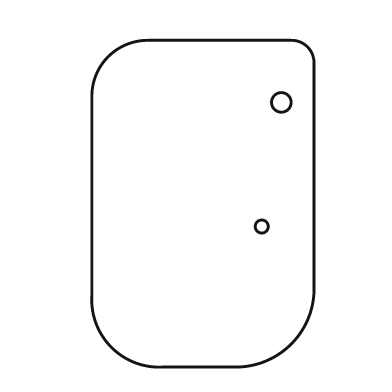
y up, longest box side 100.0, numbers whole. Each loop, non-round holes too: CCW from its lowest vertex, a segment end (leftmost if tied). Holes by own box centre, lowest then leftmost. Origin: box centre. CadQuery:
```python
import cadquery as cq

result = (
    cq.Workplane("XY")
    .moveTo(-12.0, -50.0)
    .lineTo(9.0, -50.0)
    .threePointArc((27.0, -43.0), (34.0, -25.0))
    .lineTo(34.0, 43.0)
    .threePointArc((32.0, 48.0), (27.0, 50.0))
    .lineTo(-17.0, 50.0)
    .threePointArc((-29.0, 45.0), (-34.0, 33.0))
    .lineTo(-34.0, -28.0)
    .threePointArc((-28.0, -44.0), (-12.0, -50.0))
    .close()
    .moveTo(18.0, -7.0)
    .circle(2.0)
    .moveTo(24.0, 31.0)
    .circle(3.0)
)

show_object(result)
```